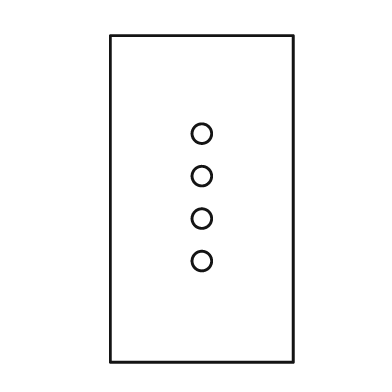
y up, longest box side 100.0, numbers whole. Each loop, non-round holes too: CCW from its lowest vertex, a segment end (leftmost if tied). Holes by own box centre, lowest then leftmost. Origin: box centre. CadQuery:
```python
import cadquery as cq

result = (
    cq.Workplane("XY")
    .moveTo(-28.0, -50.0)
    .lineTo(28.0, -50.0)
    .lineTo(28.0, 50.0)
    .lineTo(-28.0, 50.0)
    .close()
    .moveTo(0.0, -19.0)
    .circle(3.0)
    .moveTo(0.0, -6.0)
    .circle(3.0)
    .moveTo(0.0, 7.0)
    .circle(3.0)
    .moveTo(0.0, 20.0)
    .circle(3.0)
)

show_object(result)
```